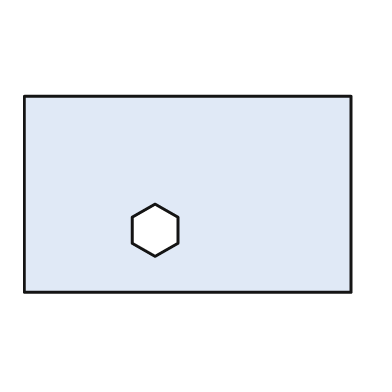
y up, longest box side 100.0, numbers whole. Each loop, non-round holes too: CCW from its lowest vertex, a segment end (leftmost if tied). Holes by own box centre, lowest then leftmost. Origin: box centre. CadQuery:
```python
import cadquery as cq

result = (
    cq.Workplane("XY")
    .moveTo(-50.0, -30.0)
    .lineTo(50.0, -30.0)
    .lineTo(50.0, 30.0)
    .lineTo(-50.0, 30.0)
    .close()
    .moveTo(-10.0, -19.0)
    .lineTo(-3.0, -15.0)
    .lineTo(-3.0, -7.0)
    .lineTo(-10.0, -3.0)
    .lineTo(-17.0, -7.0)
    .lineTo(-17.0, -15.0)
    .close()
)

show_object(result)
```